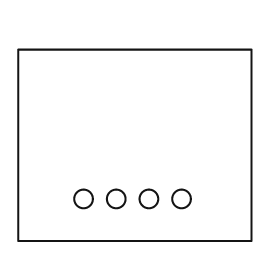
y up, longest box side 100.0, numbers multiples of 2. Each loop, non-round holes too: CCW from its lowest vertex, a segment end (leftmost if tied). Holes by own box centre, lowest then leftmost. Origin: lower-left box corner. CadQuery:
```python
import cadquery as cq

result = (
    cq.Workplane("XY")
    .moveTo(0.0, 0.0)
    .lineTo(100.0, 0.0)
    .lineTo(100.0, 82.0)
    .lineTo(0.0, 82.0)
    .close()
    .moveTo(28.0, 18.0)
    .circle(4.0)
    .moveTo(42.0, 18.0)
    .circle(4.0)
    .moveTo(56.0, 18.0)
    .circle(4.0)
    .moveTo(70.0, 18.0)
    .circle(4.0)
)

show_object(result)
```